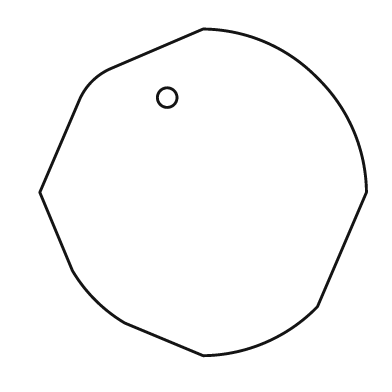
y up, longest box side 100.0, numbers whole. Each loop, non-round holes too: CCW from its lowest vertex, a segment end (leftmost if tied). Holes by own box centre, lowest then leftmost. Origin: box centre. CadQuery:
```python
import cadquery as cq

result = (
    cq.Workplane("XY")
    .moveTo(0.0, -50.0)
    .threePointArc((19.0, -46.0), (35.0, -35.0))
    .lineTo(50.0, 0.0)
    .threePointArc((46.0, 19.0), (35.0, 35.0))
    .threePointArc((19.0, 46.0), (0.0, 50.0))
    .lineTo(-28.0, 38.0)
    .threePointArc((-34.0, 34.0), (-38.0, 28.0))
    .lineTo(-50.0, 0.0)
    .lineTo(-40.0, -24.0)
    .threePointArc((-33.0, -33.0), (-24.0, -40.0))
    .close()
    .moveTo(-11.0, 29.0)
    .circle(3.0)
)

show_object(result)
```